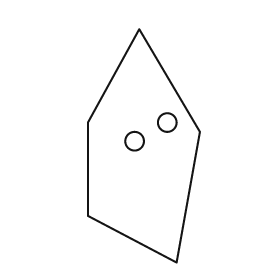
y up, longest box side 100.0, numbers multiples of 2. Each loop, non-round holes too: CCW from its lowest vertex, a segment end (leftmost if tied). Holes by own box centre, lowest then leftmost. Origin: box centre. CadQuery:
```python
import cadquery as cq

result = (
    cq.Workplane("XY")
    .moveTo(14.0, -50.0)
    .lineTo(24.0, 6.0)
    .lineTo(-2.0, 50.0)
    .lineTo(-24.0, 10.0)
    .lineTo(-24.0, -30.0)
    .close()
    .moveTo(-4.0, 2.0)
    .circle(4.0)
    .moveTo(10.0, 10.0)
    .circle(4.0)
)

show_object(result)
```